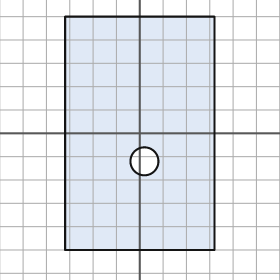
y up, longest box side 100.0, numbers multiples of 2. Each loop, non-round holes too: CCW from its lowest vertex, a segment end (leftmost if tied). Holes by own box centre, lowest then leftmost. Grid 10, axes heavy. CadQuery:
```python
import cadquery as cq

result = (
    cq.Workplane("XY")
    .moveTo(-32.0, -50.0)
    .lineTo(32.0, -50.0)
    .lineTo(32.0, 50.0)
    .lineTo(-32.0, 50.0)
    .close()
    .moveTo(2.0, -12.0)
    .circle(6.0)
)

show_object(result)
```